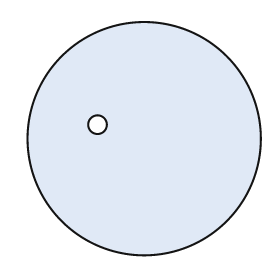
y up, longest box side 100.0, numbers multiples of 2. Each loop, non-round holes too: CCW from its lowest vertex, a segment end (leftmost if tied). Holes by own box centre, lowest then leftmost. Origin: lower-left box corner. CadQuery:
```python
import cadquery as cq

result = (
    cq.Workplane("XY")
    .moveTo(50.0, 50.0)
    .circle(50.0)
    .moveTo(30.0, 56.0)
    .circle(4.0)
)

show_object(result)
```